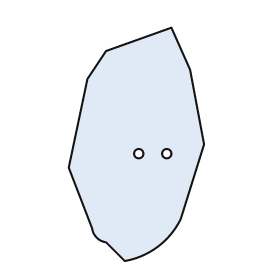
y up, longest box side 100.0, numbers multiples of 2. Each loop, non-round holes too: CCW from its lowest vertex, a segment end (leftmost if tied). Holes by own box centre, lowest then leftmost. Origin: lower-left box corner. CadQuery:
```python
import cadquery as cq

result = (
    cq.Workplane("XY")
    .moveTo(24.0, 0.0)
    .threePointArc((38.0, 6.0), (48.0, 18.0))
    .lineTo(58.0, 50.0)
    .lineTo(52.0, 82.0)
    .lineTo(44.0, 100.0)
    .lineTo(16.0, 90.0)
    .lineTo(8.0, 78.0)
    .lineTo(0.0, 40.0)
    .lineTo(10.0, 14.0)
    .threePointArc((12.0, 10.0), (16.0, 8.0))
    .close()
    .moveTo(30.0, 46.0)
    .circle(2.0)
    .moveTo(42.0, 46.0)
    .circle(2.0)
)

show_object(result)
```